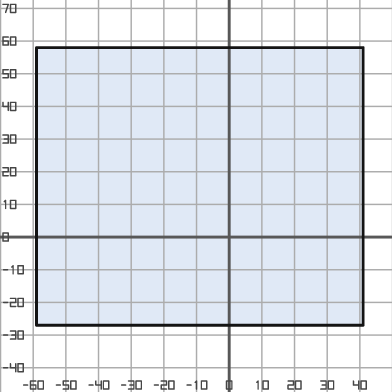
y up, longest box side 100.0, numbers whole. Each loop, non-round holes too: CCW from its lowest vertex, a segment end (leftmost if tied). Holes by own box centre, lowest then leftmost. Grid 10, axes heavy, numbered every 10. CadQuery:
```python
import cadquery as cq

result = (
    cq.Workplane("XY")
    .moveTo(-59.0, -27.0)
    .lineTo(41.0, -27.0)
    .lineTo(41.0, 58.0)
    .lineTo(-59.0, 58.0)
    .close()
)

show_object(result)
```